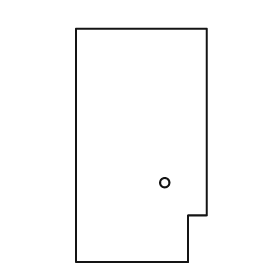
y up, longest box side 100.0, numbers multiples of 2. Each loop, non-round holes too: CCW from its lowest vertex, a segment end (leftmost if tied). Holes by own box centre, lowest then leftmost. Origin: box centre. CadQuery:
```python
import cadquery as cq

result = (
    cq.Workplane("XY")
    .moveTo(-28.0, -50.0)
    .lineTo(20.0, -50.0)
    .lineTo(20.0, -30.0)
    .lineTo(28.0, -30.0)
    .lineTo(28.0, 50.0)
    .lineTo(-28.0, 50.0)
    .close()
    .moveTo(10.0, -16.0)
    .circle(2.0)
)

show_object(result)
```